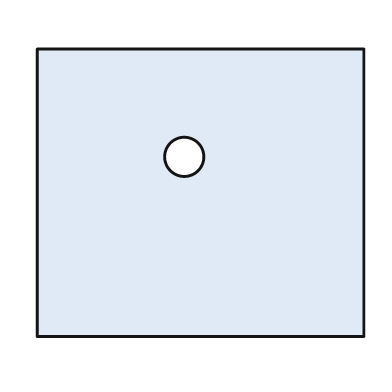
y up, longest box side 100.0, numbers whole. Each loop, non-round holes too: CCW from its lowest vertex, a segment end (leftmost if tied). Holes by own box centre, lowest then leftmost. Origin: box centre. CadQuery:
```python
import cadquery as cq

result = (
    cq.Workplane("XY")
    .moveTo(-50.0, -44.0)
    .lineTo(50.0, -44.0)
    .lineTo(50.0, 44.0)
    .lineTo(-50.0, 44.0)
    .close()
    .moveTo(-5.0, 11.0)
    .circle(6.0)
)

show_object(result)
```